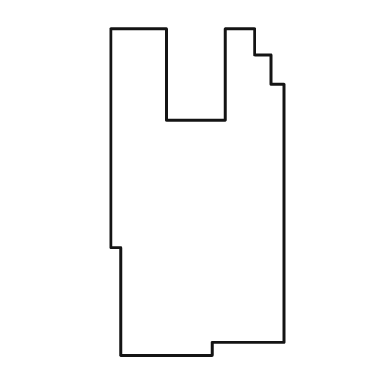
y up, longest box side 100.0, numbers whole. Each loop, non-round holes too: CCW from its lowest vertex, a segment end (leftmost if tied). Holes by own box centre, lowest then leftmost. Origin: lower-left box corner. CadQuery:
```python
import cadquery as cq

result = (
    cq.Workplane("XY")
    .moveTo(3.0, 0.0)
    .lineTo(31.0, 0.0)
    .lineTo(31.0, 4.0)
    .lineTo(53.0, 4.0)
    .lineTo(53.0, 83.0)
    .lineTo(49.0, 83.0)
    .lineTo(49.0, 92.0)
    .lineTo(44.0, 92.0)
    .lineTo(44.0, 100.0)
    .lineTo(35.0, 100.0)
    .lineTo(35.0, 72.0)
    .lineTo(17.0, 72.0)
    .lineTo(17.0, 100.0)
    .lineTo(0.0, 100.0)
    .lineTo(0.0, 33.0)
    .lineTo(3.0, 33.0)
    .close()
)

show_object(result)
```